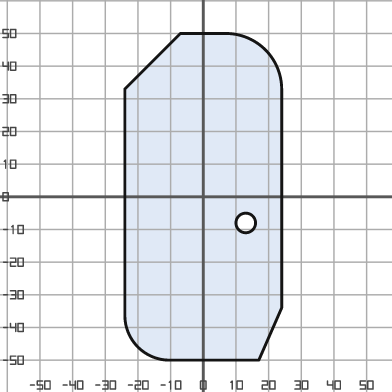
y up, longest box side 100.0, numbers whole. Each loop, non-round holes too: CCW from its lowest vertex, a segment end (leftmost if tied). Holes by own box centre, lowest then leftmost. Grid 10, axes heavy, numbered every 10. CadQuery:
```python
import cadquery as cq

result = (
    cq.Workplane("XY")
    .moveTo(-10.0, -50.0)
    .lineTo(17.0, -50.0)
    .lineTo(24.0, -34.0)
    .lineTo(24.0, 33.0)
    .threePointArc((19.0, 45.0), (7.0, 50.0))
    .lineTo(-7.0, 50.0)
    .lineTo(-24.0, 33.0)
    .lineTo(-24.0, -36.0)
    .threePointArc((-20.0, -46.0), (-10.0, -50.0))
    .close()
    .moveTo(13.0, -8.0)
    .circle(3.0)
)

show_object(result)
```